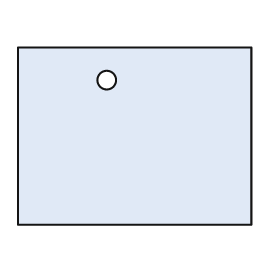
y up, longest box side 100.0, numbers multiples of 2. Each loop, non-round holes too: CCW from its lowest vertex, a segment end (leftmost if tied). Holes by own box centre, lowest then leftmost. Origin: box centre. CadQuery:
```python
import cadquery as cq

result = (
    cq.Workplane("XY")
    .moveTo(-50.0, -38.0)
    .lineTo(50.0, -38.0)
    .lineTo(50.0, 38.0)
    .lineTo(-50.0, 38.0)
    .close()
    .moveTo(-12.0, 24.0)
    .circle(4.0)
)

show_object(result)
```